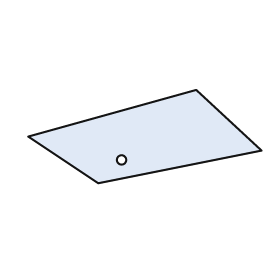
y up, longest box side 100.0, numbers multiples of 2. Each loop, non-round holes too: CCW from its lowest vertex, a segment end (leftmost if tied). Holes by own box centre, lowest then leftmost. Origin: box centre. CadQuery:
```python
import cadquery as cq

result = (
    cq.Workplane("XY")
    .moveTo(-20.0, -20.0)
    .lineTo(50.0, -6.0)
    .lineTo(22.0, 20.0)
    .lineTo(-50.0, 0.0)
    .close()
    .moveTo(-10.0, -10.0)
    .circle(2.0)
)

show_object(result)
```